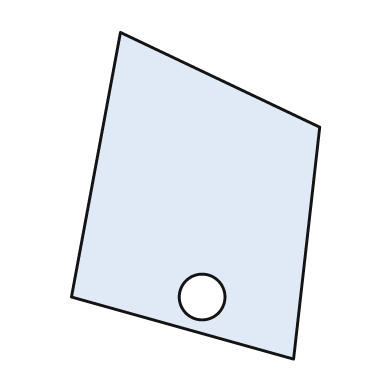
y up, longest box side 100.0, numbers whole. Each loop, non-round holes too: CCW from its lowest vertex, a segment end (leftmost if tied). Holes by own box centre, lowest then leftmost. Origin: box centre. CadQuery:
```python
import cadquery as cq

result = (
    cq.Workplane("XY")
    .moveTo(30.0, -50.0)
    .lineTo(38.0, 21.0)
    .lineTo(-23.0, 50.0)
    .lineTo(-38.0, -31.0)
    .close()
    .moveTo(2.0, -31.0)
    .circle(7.0)
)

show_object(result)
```